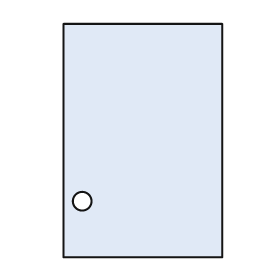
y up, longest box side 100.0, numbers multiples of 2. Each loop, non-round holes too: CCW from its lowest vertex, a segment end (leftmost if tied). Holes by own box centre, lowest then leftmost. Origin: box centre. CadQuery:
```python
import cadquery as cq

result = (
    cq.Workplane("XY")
    .moveTo(-34.0, -50.0)
    .lineTo(34.0, -50.0)
    .lineTo(34.0, 50.0)
    .lineTo(-34.0, 50.0)
    .close()
    .moveTo(-26.0, -26.0)
    .circle(4.0)
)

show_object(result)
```